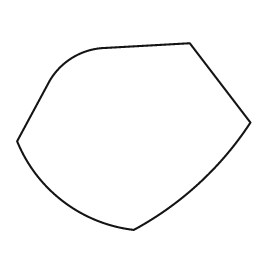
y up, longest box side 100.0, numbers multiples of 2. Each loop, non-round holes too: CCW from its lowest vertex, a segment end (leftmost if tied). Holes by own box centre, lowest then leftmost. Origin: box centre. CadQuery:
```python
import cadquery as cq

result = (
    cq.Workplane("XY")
    .moveTo(0.0, -40.0)
    .threePointArc((28.0, -20.0), (50.0, 6.0))
    .lineTo(24.0, 40.0)
    .lineTo(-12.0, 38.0)
    .threePointArc((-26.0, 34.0), (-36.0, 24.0))
    .lineTo(-50.0, -2.0)
    .threePointArc((-30.0, -28.0), (0.0, -40.0))
    .close()
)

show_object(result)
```